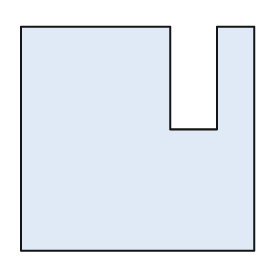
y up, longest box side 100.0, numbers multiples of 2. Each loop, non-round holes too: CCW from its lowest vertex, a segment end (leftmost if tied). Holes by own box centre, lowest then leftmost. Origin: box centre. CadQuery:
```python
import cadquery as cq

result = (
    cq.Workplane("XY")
    .moveTo(-50.0, -48.0)
    .lineTo(50.0, -48.0)
    .lineTo(50.0, 48.0)
    .lineTo(34.0, 48.0)
    .lineTo(34.0, 4.0)
    .lineTo(14.0, 4.0)
    .lineTo(14.0, 48.0)
    .lineTo(-50.0, 48.0)
    .close()
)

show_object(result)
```